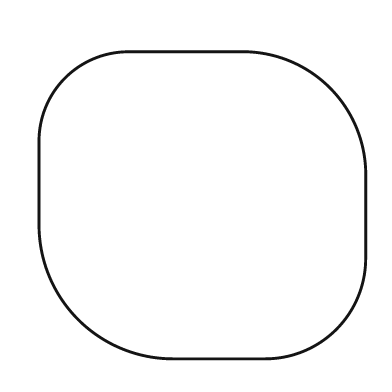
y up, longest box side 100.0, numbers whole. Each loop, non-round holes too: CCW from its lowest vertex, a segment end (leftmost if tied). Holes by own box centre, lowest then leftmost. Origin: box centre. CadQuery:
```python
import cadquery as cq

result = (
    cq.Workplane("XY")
    .moveTo(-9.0, -47.0)
    .lineTo(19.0, -47.0)
    .threePointArc((41.0, -38.0), (50.0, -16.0))
    .lineTo(50.0, 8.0)
    .threePointArc((39.0, 36.0), (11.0, 47.0))
    .lineTo(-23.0, 47.0)
    .threePointArc((-42.0, 39.0), (-50.0, 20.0))
    .lineTo(-50.0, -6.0)
    .threePointArc((-38.0, -35.0), (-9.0, -47.0))
    .close()
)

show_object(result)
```